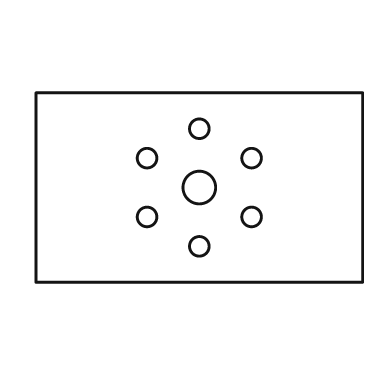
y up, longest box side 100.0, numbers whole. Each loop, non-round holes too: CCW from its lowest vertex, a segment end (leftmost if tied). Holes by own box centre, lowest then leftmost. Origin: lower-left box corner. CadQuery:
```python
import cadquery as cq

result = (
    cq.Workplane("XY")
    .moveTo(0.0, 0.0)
    .lineTo(100.0, 0.0)
    .lineTo(100.0, 58.0)
    .lineTo(0.0, 58.0)
    .close()
    .moveTo(50.0, 11.0)
    .circle(3.0)
    .moveTo(34.0, 20.0)
    .circle(3.0)
    .moveTo(66.0, 20.0)
    .circle(3.0)
    .moveTo(50.0, 29.0)
    .circle(5.0)
    .moveTo(34.0, 38.0)
    .circle(3.0)
    .moveTo(66.0, 38.0)
    .circle(3.0)
    .moveTo(50.0, 47.0)
    .circle(3.0)
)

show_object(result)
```